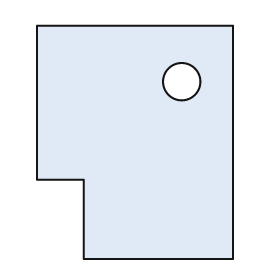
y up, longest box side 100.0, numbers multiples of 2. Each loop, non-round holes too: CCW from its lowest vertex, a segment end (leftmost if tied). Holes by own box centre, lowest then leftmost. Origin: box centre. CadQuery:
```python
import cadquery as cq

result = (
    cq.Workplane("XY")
    .moveTo(-22.0, -50.0)
    .lineTo(42.0, -50.0)
    .lineTo(42.0, 50.0)
    .lineTo(-42.0, 50.0)
    .lineTo(-42.0, -16.0)
    .lineTo(-22.0, -16.0)
    .close()
    .moveTo(20.0, 26.0)
    .circle(8.0)
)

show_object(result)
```